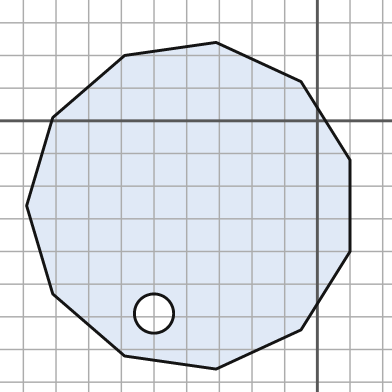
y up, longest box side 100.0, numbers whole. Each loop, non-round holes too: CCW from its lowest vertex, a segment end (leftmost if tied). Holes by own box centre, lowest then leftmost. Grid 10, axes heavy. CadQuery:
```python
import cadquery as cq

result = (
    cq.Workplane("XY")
    .moveTo(-31.0, -76.0)
    .lineTo(-5.0, -64.0)
    .lineTo(10.0, -40.0)
    .lineTo(10.0, -12.0)
    .lineTo(-5.0, 12.0)
    .lineTo(-31.0, 24.0)
    .lineTo(-59.0, 20.0)
    .lineTo(-81.0, 1.0)
    .lineTo(-89.0, -26.0)
    .lineTo(-81.0, -53.0)
    .lineTo(-59.0, -72.0)
    .close()
    .moveTo(-50.0, -59.0)
    .circle(6.0)
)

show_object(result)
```